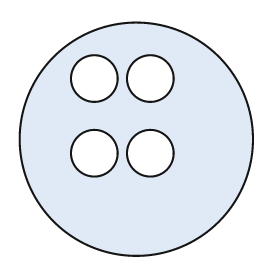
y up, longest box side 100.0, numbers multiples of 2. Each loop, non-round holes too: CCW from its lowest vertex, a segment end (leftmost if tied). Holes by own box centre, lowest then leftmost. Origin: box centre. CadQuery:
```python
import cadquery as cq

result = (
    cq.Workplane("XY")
    .moveTo(0.0, 0.0)
    .circle(50.0)
    .moveTo(-18.0, -6.0)
    .circle(10.0)
    .moveTo(6.0, -6.0)
    .circle(10.0)
    .moveTo(-18.0, 26.0)
    .circle(10.0)
    .moveTo(6.0, 26.0)
    .circle(10.0)
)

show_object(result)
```